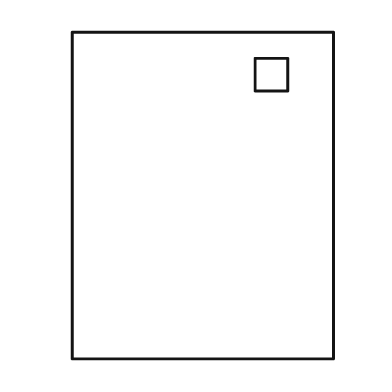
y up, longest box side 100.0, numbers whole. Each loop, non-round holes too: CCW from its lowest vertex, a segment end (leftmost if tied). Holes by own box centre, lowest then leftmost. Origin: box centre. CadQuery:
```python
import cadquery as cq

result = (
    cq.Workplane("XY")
    .moveTo(-40.0, -50.0)
    .lineTo(40.0, -50.0)
    .lineTo(40.0, 50.0)
    .lineTo(-40.0, 50.0)
    .close()
    .moveTo(16.0, 32.0)
    .lineTo(26.0, 32.0)
    .lineTo(26.0, 42.0)
    .lineTo(16.0, 42.0)
    .close()
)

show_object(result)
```